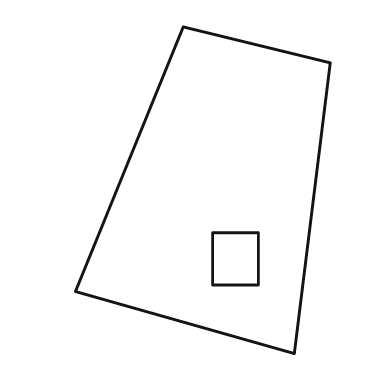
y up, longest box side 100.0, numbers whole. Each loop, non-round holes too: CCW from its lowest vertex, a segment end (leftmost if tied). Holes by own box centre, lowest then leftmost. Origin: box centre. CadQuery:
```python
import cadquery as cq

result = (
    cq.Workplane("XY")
    .moveTo(28.0, -50.0)
    .lineTo(39.0, 39.0)
    .lineTo(-6.0, 50.0)
    .lineTo(-39.0, -31.0)
    .close()
    .moveTo(3.0, -29.0)
    .lineTo(17.0, -29.0)
    .lineTo(17.0, -13.0)
    .lineTo(3.0, -13.0)
    .close()
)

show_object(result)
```